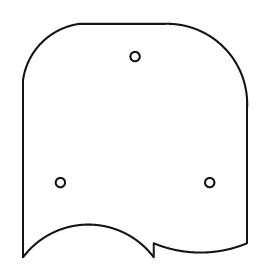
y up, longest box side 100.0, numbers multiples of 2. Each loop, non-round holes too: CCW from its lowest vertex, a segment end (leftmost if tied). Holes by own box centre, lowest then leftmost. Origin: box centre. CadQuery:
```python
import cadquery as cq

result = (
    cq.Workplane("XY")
    .moveTo(-48.0, -50.0)
    .threePointArc((-20.0, -36.0), (8.0, -50.0))
    .lineTo(8.0, -44.0)
    .threePointArc((28.0, -48.0), (48.0, -44.0))
    .lineTo(48.0, 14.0)
    .threePointArc((38.0, 40.0), (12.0, 50.0))
    .lineTo(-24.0, 50.0)
    .threePointArc((-40.0, 42.0), (-48.0, 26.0))
    .close()
    .moveTo(-32.0, -18.0)
    .circle(2.0)
    .moveTo(32.0, -18.0)
    .circle(2.0)
    .moveTo(0.0, 36.0)
    .circle(2.0)
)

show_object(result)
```